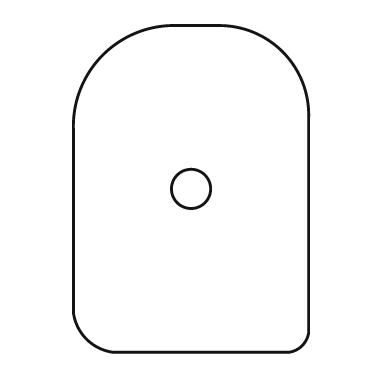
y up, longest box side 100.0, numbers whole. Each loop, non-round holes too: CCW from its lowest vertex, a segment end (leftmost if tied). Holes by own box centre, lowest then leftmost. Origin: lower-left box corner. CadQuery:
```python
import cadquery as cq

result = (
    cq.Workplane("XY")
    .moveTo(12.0, 0.0)
    .lineTo(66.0, 0.0)
    .threePointArc((70.0, 2.0), (72.0, 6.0))
    .lineTo(72.0, 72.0)
    .threePointArc((64.0, 92.0), (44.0, 100.0))
    .lineTo(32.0, 100.0)
    .threePointArc((9.0, 91.0), (0.0, 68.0))
    .lineTo(0.0, 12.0)
    .threePointArc((4.0, 4.0), (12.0, 0.0))
    .close()
    .moveTo(36.0, 50.0)
    .circle(6.0)
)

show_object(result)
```